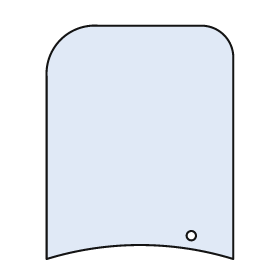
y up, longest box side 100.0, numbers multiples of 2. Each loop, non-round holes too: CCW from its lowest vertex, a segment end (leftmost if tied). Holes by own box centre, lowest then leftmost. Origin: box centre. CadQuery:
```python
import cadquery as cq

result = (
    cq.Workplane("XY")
    .moveTo(-40.0, -50.0)
    .threePointArc((0.0, -44.0), (40.0, -50.0))
    .lineTo(40.0, 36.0)
    .threePointArc((36.0, 46.0), (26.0, 50.0))
    .lineTo(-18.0, 50.0)
    .threePointArc((-34.0, 44.0), (-40.0, 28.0))
    .close()
    .moveTo(22.0, -40.0)
    .circle(2.0)
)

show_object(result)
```